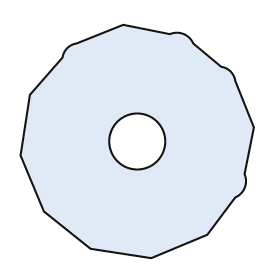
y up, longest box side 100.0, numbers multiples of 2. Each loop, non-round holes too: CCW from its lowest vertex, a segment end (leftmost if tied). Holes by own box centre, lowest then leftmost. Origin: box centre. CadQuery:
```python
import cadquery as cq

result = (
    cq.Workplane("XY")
    .moveTo(6.0, -50.0)
    .lineTo(30.0, -40.0)
    .lineTo(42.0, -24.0)
    .threePointArc((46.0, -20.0), (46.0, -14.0))
    .lineTo(50.0, 6.0)
    .lineTo(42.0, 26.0)
    .threePointArc((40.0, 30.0), (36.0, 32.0))
    .lineTo(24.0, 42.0)
    .threePointArc((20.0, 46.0), (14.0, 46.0))
    .lineTo(-6.0, 50.0)
    .lineTo(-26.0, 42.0)
    .threePointArc((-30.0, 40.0), (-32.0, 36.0))
    .lineTo(-46.0, 20.0)
    .lineTo(-50.0, -6.0)
    .lineTo(-40.0, -30.0)
    .lineTo(-20.0, -46.0)
    .close()
    .moveTo(0.0, 0.0)
    .circle(12.0)
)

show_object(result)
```